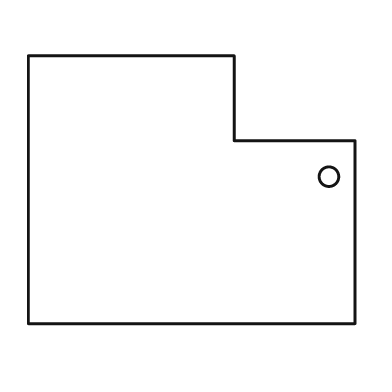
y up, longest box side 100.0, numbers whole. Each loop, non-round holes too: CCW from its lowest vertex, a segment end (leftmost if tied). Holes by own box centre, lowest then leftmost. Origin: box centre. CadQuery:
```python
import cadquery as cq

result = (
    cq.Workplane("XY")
    .moveTo(-50.0, -41.0)
    .lineTo(50.0, -41.0)
    .lineTo(50.0, 15.0)
    .lineTo(13.0, 15.0)
    .lineTo(13.0, 41.0)
    .lineTo(-50.0, 41.0)
    .close()
    .moveTo(42.0, 4.0)
    .circle(3.0)
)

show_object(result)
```